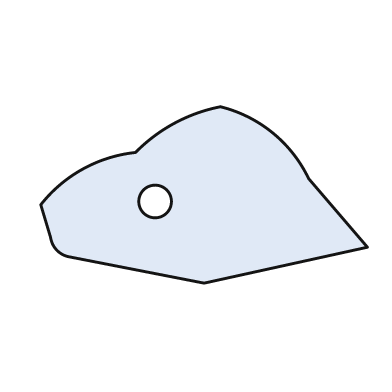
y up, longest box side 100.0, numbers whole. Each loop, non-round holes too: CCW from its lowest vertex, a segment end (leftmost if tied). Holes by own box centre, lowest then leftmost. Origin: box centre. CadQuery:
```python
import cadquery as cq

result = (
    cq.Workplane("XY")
    .moveTo(0.0, -27.0)
    .lineTo(50.0, -16.0)
    .lineTo(32.0, 5.0)
    .threePointArc((21.0, 19.0), (5.0, 27.0))
    .threePointArc((-9.0, 22.0), (-21.0, 13.0))
    .threePointArc((-37.0, 8.0), (-50.0, -3.0))
    .lineTo(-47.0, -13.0)
    .threePointArc((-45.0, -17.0), (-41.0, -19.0))
    .close()
    .moveTo(-15.0, -2.0)
    .circle(5.0)
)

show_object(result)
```